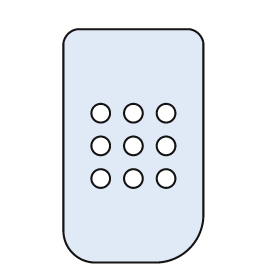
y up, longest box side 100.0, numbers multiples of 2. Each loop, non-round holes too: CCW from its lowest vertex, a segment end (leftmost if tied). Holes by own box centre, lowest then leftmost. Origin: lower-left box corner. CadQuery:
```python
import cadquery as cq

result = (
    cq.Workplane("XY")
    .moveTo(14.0, 0.0)
    .lineTo(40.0, 0.0)
    .threePointArc((54.0, 6.0), (60.0, 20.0))
    .lineTo(60.0, 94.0)
    .threePointArc((58.0, 98.0), (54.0, 100.0))
    .lineTo(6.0, 100.0)
    .threePointArc((2.0, 98.0), (0.0, 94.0))
    .lineTo(0.0, 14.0)
    .threePointArc((4.0, 4.0), (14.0, 0.0))
    .close()
    .moveTo(16.0, 36.0)
    .circle(4.0)
    .moveTo(30.0, 36.0)
    .circle(4.0)
    .moveTo(44.0, 36.0)
    .circle(4.0)
    .moveTo(16.0, 50.0)
    .circle(4.0)
    .moveTo(30.0, 50.0)
    .circle(4.0)
    .moveTo(44.0, 50.0)
    .circle(4.0)
    .moveTo(16.0, 64.0)
    .circle(4.0)
    .moveTo(30.0, 64.0)
    .circle(4.0)
    .moveTo(44.0, 64.0)
    .circle(4.0)
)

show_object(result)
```